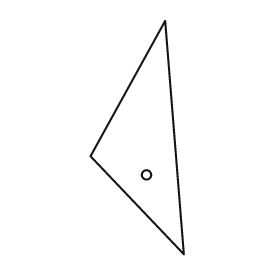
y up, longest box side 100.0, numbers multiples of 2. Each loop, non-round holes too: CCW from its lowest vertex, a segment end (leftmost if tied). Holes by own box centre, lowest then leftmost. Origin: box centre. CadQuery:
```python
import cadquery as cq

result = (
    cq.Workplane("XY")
    .moveTo(20.0, -50.0)
    .lineTo(12.0, 50.0)
    .lineTo(-20.0, -8.0)
    .close()
    .moveTo(4.0, -16.0)
    .circle(2.0)
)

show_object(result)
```